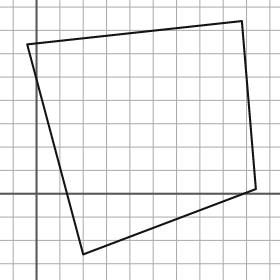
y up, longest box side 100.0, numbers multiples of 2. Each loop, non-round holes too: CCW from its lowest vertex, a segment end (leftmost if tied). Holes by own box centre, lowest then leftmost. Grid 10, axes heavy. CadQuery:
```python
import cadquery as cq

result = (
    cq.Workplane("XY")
    .moveTo(20.0, -26.0)
    .lineTo(94.0, 2.0)
    .lineTo(88.0, 74.0)
    .lineTo(-4.0, 64.0)
    .close()
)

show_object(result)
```